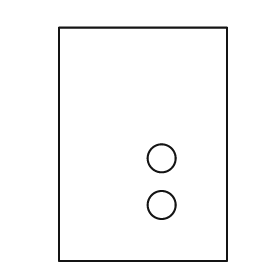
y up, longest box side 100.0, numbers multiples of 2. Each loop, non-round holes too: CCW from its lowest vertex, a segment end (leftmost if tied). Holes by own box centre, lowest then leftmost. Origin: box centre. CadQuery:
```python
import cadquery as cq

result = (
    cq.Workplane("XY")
    .moveTo(-36.0, -50.0)
    .lineTo(36.0, -50.0)
    .lineTo(36.0, 50.0)
    .lineTo(-36.0, 50.0)
    .close()
    .moveTo(8.0, -26.0)
    .circle(6.0)
    .moveTo(8.0, -6.0)
    .circle(6.0)
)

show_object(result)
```